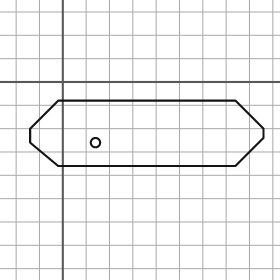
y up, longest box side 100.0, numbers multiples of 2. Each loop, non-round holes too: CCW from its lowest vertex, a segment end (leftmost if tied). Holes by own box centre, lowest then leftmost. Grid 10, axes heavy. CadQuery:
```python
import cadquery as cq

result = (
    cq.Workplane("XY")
    .moveTo(-2.0, -36.0)
    .lineTo(74.0, -36.0)
    .lineTo(86.0, -24.0)
    .lineTo(86.0, -20.0)
    .lineTo(74.0, -8.0)
    .lineTo(-2.0, -8.0)
    .lineTo(-14.0, -20.0)
    .lineTo(-14.0, -26.0)
    .close()
    .moveTo(14.0, -26.0)
    .circle(2.0)
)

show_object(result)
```